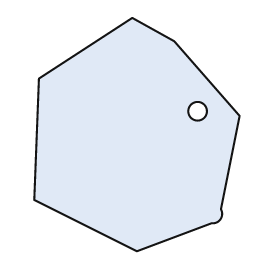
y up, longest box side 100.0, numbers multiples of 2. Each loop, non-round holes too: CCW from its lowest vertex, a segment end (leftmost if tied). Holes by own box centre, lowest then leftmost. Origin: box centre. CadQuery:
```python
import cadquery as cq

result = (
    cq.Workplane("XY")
    .moveTo(0.0, -50.0)
    .lineTo(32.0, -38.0)
    .threePointArc((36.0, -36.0), (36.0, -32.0))
    .lineTo(44.0, 8.0)
    .lineTo(16.0, 40.0)
    .lineTo(-2.0, 50.0)
    .lineTo(-42.0, 24.0)
    .lineTo(-44.0, -28.0)
    .close()
    .moveTo(26.0, 10.0)
    .circle(4.0)
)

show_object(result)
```